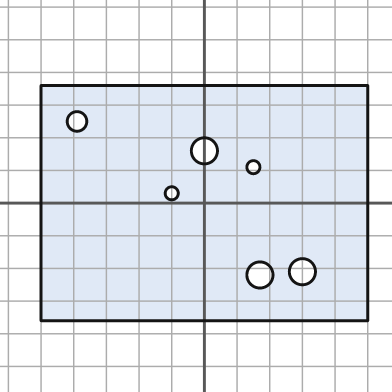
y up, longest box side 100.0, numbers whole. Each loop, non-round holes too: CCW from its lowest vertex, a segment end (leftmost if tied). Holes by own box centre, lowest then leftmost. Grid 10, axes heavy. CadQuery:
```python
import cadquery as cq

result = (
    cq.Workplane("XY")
    .moveTo(-50.0, -36.0)
    .lineTo(50.0, -36.0)
    .lineTo(50.0, 36.0)
    .lineTo(-50.0, 36.0)
    .close()
    .moveTo(17.0, -22.0)
    .circle(4.0)
    .moveTo(30.0, -21.0)
    .circle(4.0)
    .moveTo(-10.0, 3.0)
    .circle(2.0)
    .moveTo(15.0, 11.0)
    .circle(2.0)
    .moveTo(0.0, 16.0)
    .circle(4.0)
    .moveTo(-39.0, 25.0)
    .circle(3.0)
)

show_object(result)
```